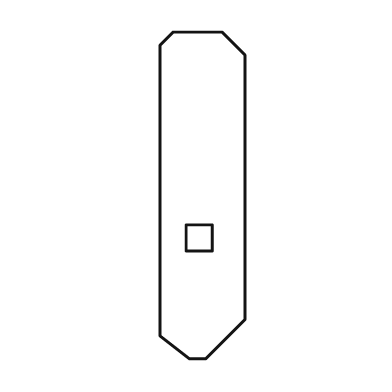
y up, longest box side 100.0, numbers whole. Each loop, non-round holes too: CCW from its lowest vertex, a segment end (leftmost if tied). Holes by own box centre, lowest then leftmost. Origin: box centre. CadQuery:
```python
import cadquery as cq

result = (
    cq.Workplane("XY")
    .moveTo(-4.0, -50.0)
    .lineTo(1.0, -50.0)
    .lineTo(13.0, -38.0)
    .lineTo(13.0, 43.0)
    .lineTo(6.0, 50.0)
    .lineTo(-9.0, 50.0)
    .lineTo(-13.0, 46.0)
    .lineTo(-13.0, -43.0)
    .close()
    .moveTo(-5.0, -17.0)
    .lineTo(3.0, -17.0)
    .lineTo(3.0, -9.0)
    .lineTo(-5.0, -9.0)
    .close()
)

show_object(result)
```